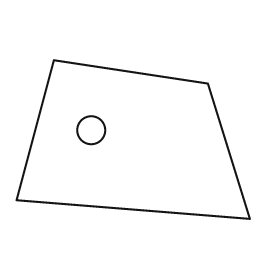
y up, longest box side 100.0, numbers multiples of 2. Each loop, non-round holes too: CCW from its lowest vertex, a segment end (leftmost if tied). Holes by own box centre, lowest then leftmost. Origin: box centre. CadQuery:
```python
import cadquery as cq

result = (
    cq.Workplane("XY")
    .moveTo(50.0, -34.0)
    .lineTo(32.0, 24.0)
    .lineTo(-34.0, 34.0)
    .lineTo(-50.0, -26.0)
    .close()
    .moveTo(-18.0, 4.0)
    .circle(6.0)
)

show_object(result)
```